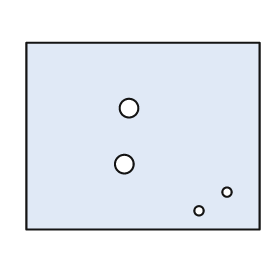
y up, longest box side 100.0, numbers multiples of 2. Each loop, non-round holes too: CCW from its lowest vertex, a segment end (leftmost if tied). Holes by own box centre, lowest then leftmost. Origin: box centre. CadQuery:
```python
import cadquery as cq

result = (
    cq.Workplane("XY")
    .moveTo(-50.0, -40.0)
    .lineTo(50.0, -40.0)
    .lineTo(50.0, 40.0)
    .lineTo(-50.0, 40.0)
    .close()
    .moveTo(24.0, -32.0)
    .circle(2.0)
    .moveTo(36.0, -24.0)
    .circle(2.0)
    .moveTo(-8.0, -12.0)
    .circle(4.0)
    .moveTo(-6.0, 12.0)
    .circle(4.0)
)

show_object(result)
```